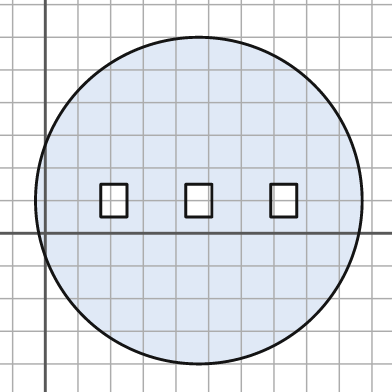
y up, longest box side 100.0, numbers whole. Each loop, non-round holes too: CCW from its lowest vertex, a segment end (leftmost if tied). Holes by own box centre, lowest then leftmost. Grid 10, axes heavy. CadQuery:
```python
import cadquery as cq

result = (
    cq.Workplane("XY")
    .moveTo(47.0, 10.0)
    .circle(50.0)
    .moveTo(17.0, 5.0)
    .lineTo(25.0, 5.0)
    .lineTo(25.0, 15.0)
    .lineTo(17.0, 15.0)
    .close()
    .moveTo(43.0, 5.0)
    .lineTo(51.0, 5.0)
    .lineTo(51.0, 15.0)
    .lineTo(43.0, 15.0)
    .close()
    .moveTo(69.0, 5.0)
    .lineTo(77.0, 5.0)
    .lineTo(77.0, 15.0)
    .lineTo(69.0, 15.0)
    .close()
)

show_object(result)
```